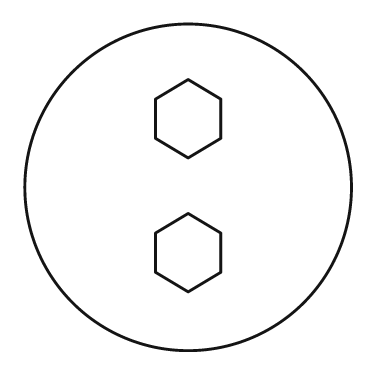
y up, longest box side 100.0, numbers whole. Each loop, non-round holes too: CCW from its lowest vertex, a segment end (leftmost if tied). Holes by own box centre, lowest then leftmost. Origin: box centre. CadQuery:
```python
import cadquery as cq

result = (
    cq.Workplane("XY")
    .moveTo(0.0, 0.0)
    .circle(50.0)
    .moveTo(0.0, -32.0)
    .lineTo(10.0, -26.0)
    .lineTo(10.0, -14.0)
    .lineTo(0.0, -8.0)
    .lineTo(-10.0, -14.0)
    .lineTo(-10.0, -26.0)
    .close()
    .moveTo(0.0, 9.0)
    .lineTo(10.0, 15.0)
    .lineTo(10.0, 27.0)
    .lineTo(0.0, 33.0)
    .lineTo(-10.0, 27.0)
    .lineTo(-10.0, 15.0)
    .close()
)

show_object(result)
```